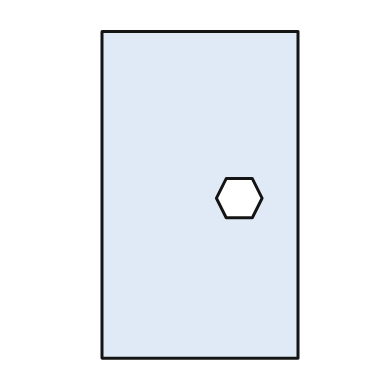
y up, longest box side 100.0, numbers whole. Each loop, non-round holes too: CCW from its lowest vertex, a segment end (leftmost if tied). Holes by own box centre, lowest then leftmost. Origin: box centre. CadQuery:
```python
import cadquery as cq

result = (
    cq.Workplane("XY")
    .moveTo(-30.0, -50.0)
    .lineTo(30.0, -50.0)
    .lineTo(30.0, 50.0)
    .lineTo(-30.0, 50.0)
    .close()
    .moveTo(8.0, -7.0)
    .lineTo(16.0, -7.0)
    .lineTo(19.0, -1.0)
    .lineTo(16.0, 5.0)
    .lineTo(8.0, 5.0)
    .lineTo(5.0, -1.0)
    .close()
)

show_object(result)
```